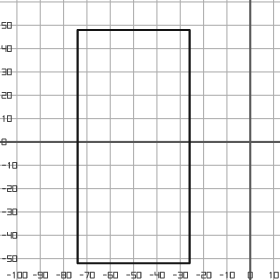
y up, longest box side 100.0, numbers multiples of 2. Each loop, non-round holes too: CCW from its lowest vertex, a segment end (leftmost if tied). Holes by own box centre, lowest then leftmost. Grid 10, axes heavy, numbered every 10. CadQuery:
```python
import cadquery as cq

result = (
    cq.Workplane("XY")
    .moveTo(-74.0, -52.0)
    .lineTo(-26.0, -52.0)
    .lineTo(-26.0, 48.0)
    .lineTo(-74.0, 48.0)
    .close()
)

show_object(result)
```